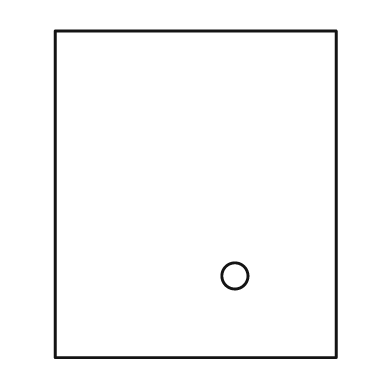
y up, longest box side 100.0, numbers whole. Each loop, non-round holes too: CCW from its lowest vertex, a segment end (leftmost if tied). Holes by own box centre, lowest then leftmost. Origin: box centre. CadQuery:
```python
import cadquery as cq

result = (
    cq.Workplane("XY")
    .moveTo(-43.0, -50.0)
    .lineTo(43.0, -50.0)
    .lineTo(43.0, 50.0)
    .lineTo(-43.0, 50.0)
    .close()
    .moveTo(12.0, -25.0)
    .circle(4.0)
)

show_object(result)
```